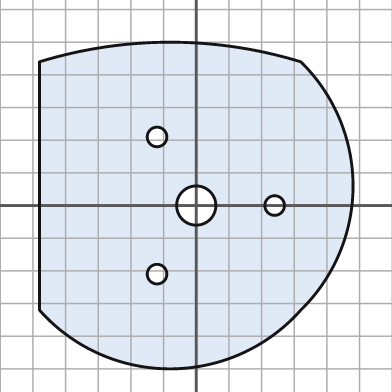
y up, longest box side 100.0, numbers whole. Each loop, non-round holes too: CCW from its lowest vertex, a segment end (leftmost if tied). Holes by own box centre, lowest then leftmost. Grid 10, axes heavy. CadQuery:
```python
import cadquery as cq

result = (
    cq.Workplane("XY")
    .moveTo(-48.0, -32.0)
    .threePointArc((-8.0, -50.0), (32.0, -32.0))
    .threePointArc((48.0, 6.0), (32.0, 44.0))
    .threePointArc((-8.0, 50.0), (-48.0, 44.0))
    .close()
    .moveTo(-12.0, -21.0)
    .circle(3.0)
    .moveTo(0.0, 0.0)
    .circle(6.0)
    .moveTo(24.0, 0.0)
    .circle(3.0)
    .moveTo(-12.0, 21.0)
    .circle(3.0)
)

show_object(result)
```